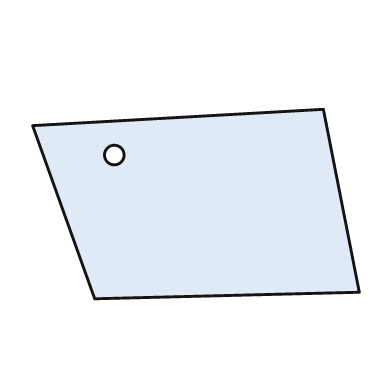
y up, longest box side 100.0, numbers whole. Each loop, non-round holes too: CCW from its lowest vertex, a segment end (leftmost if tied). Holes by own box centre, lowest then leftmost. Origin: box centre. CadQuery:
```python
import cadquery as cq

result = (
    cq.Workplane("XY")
    .moveTo(-31.0, -29.0)
    .lineTo(50.0, -27.0)
    .lineTo(39.0, 29.0)
    .lineTo(-50.0, 24.0)
    .close()
    .moveTo(-25.0, 15.0)
    .circle(3.0)
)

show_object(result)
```